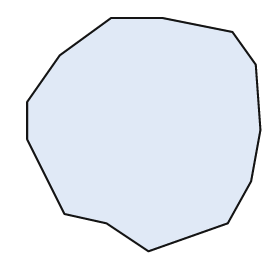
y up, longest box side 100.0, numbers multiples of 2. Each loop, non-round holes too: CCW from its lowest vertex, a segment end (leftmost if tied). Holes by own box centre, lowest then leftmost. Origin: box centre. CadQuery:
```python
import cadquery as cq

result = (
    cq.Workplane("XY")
    .moveTo(2.0, -50.0)
    .lineTo(36.0, -38.0)
    .lineTo(46.0, -20.0)
    .lineTo(50.0, 2.0)
    .lineTo(48.0, 30.0)
    .lineTo(38.0, 44.0)
    .lineTo(8.0, 50.0)
    .lineTo(-14.0, 50.0)
    .lineTo(-36.0, 34.0)
    .lineTo(-50.0, 14.0)
    .lineTo(-50.0, -2.0)
    .lineTo(-34.0, -34.0)
    .lineTo(-16.0, -38.0)
    .close()
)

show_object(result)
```